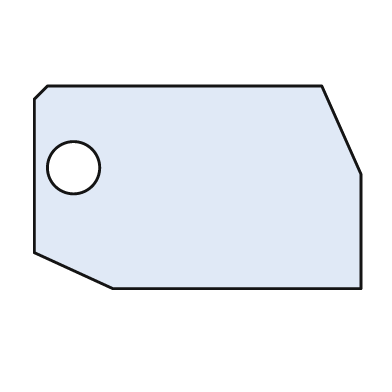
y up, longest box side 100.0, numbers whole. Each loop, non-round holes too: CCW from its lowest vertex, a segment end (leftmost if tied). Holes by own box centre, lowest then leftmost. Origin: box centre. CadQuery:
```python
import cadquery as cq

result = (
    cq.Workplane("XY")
    .moveTo(-26.0, -31.0)
    .lineTo(50.0, -31.0)
    .lineTo(50.0, 4.0)
    .lineTo(38.0, 31.0)
    .lineTo(-46.0, 31.0)
    .lineTo(-50.0, 27.0)
    .lineTo(-50.0, -20.0)
    .close()
    .moveTo(-38.0, 6.0)
    .circle(8.0)
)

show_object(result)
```